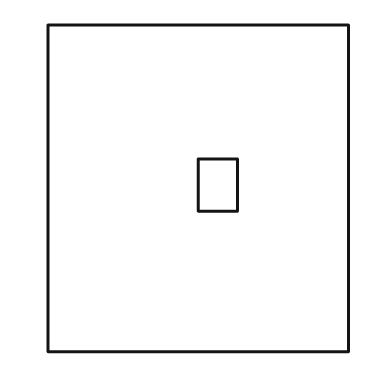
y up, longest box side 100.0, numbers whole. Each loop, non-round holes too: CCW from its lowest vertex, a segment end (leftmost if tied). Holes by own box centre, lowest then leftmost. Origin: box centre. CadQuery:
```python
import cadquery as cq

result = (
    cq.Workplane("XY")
    .moveTo(-46.0, -50.0)
    .lineTo(46.0, -50.0)
    .lineTo(46.0, 50.0)
    .lineTo(-46.0, 50.0)
    .close()
    .moveTo(0.0, -7.0)
    .lineTo(12.0, -7.0)
    .lineTo(12.0, 9.0)
    .lineTo(0.0, 9.0)
    .close()
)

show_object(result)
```